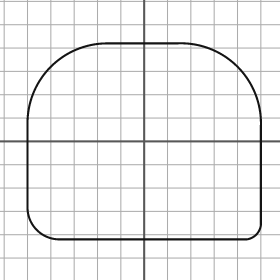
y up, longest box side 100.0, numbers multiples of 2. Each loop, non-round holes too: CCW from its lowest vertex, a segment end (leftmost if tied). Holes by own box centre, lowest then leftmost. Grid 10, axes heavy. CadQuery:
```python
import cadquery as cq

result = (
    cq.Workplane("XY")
    .moveTo(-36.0, -42.0)
    .lineTo(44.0, -42.0)
    .threePointArc((48.0, -40.0), (50.0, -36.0))
    .lineTo(50.0, 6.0)
    .threePointArc((40.0, 32.0), (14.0, 42.0))
    .lineTo(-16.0, 42.0)
    .threePointArc((-40.0, 32.0), (-50.0, 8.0))
    .lineTo(-50.0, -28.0)
    .threePointArc((-46.0, -38.0), (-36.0, -42.0))
    .close()
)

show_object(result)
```